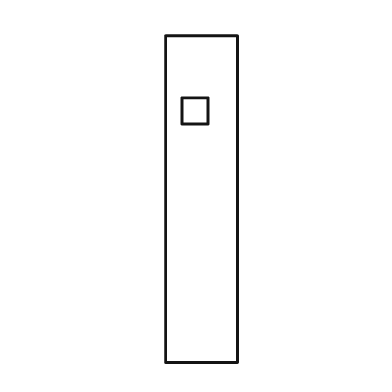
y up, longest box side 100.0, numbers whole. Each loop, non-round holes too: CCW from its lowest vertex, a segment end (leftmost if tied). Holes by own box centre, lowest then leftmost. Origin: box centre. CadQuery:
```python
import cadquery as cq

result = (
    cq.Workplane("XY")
    .moveTo(-11.0, -50.0)
    .lineTo(11.0, -50.0)
    .lineTo(11.0, 50.0)
    .lineTo(-11.0, 50.0)
    .close()
    .moveTo(-6.0, 23.0)
    .lineTo(2.0, 23.0)
    .lineTo(2.0, 31.0)
    .lineTo(-6.0, 31.0)
    .close()
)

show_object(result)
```